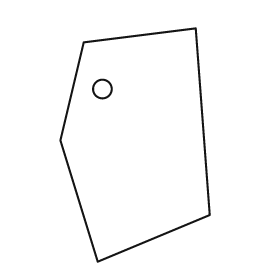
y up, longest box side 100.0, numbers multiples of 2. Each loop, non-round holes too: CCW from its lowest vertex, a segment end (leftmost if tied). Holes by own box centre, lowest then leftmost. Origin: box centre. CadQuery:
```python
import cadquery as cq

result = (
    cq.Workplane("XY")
    .moveTo(-16.0, -50.0)
    .lineTo(32.0, -30.0)
    .lineTo(26.0, 50.0)
    .lineTo(-22.0, 44.0)
    .lineTo(-32.0, 2.0)
    .close()
    .moveTo(-14.0, 24.0)
    .circle(4.0)
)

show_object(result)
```